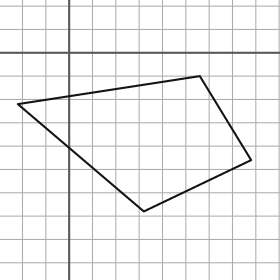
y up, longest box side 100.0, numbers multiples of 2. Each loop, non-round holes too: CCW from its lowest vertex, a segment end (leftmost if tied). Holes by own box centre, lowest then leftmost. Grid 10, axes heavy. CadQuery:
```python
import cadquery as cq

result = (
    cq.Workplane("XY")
    .moveTo(32.0, -68.0)
    .lineTo(78.0, -46.0)
    .lineTo(56.0, -10.0)
    .lineTo(-22.0, -22.0)
    .close()
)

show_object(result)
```